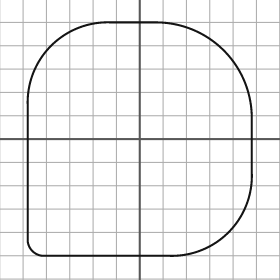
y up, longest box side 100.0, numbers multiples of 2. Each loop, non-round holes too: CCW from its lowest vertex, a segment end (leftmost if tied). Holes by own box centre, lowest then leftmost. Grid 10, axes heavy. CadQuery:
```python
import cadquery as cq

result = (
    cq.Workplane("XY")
    .moveTo(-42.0, -50.0)
    .lineTo(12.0, -50.0)
    .threePointArc((38.0, -40.0), (48.0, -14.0))
    .lineTo(48.0, 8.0)
    .threePointArc((36.0, 38.0), (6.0, 50.0))
    .lineTo(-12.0, 50.0)
    .threePointArc((-38.0, 40.0), (-48.0, 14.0))
    .lineTo(-48.0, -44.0)
    .threePointArc((-46.0, -48.0), (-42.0, -50.0))
    .close()
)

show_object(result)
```